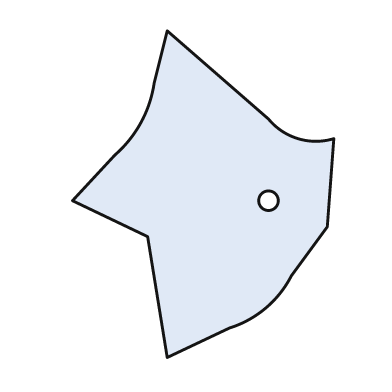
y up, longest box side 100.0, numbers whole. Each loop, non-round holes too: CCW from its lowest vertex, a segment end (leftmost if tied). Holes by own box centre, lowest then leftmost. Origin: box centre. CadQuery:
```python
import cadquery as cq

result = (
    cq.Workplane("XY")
    .moveTo(-11.0, -50.0)
    .lineTo(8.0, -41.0)
    .threePointArc((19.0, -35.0), (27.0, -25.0))
    .lineTo(38.0, -10.0)
    .lineTo(40.0, 17.0)
    .threePointArc((29.0, 17.0), (20.0, 23.0))
    .lineTo(-11.0, 50.0)
    .lineTo(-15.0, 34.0)
    .threePointArc((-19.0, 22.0), (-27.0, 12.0))
    .lineTo(-40.0, -2.0)
    .lineTo(-17.0, -13.0)
    .close()
    .moveTo(20.0, -2.0)
    .circle(3.0)
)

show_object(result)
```